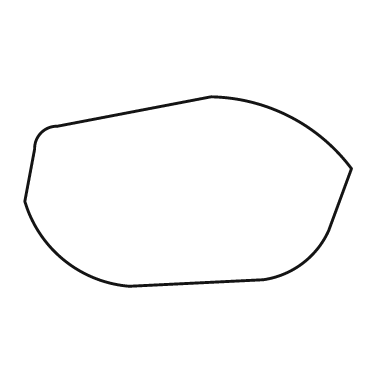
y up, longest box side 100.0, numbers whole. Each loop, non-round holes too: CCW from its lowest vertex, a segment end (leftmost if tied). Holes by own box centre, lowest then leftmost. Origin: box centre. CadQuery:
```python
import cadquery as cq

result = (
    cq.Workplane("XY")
    .moveTo(-18.0, -29.0)
    .lineTo(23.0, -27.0)
    .threePointArc((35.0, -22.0), (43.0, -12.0))
    .lineTo(50.0, 7.0)
    .threePointArc((31.0, 23.0), (7.0, 29.0))
    .lineTo(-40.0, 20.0)
    .threePointArc((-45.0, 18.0), (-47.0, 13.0))
    .lineTo(-50.0, -3.0)
    .threePointArc((-38.0, -21.0), (-18.0, -29.0))
    .close()
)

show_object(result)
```